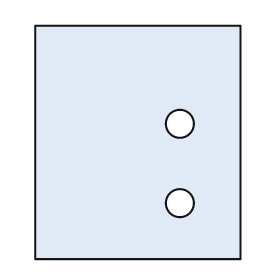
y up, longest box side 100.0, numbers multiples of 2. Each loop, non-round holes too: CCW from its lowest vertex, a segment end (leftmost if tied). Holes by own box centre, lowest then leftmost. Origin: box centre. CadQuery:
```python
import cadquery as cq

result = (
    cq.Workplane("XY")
    .moveTo(-44.0, -50.0)
    .lineTo(44.0, -50.0)
    .lineTo(44.0, 50.0)
    .lineTo(-44.0, 50.0)
    .close()
    .moveTo(18.0, -26.0)
    .circle(6.0)
    .moveTo(18.0, 8.0)
    .circle(6.0)
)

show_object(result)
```